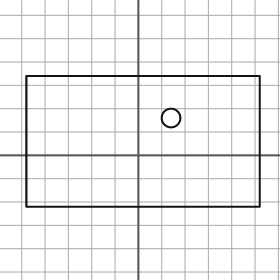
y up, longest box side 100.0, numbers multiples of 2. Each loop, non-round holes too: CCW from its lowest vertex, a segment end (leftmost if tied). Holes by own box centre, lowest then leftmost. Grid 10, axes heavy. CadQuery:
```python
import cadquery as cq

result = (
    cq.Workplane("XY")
    .moveTo(-48.0, -22.0)
    .lineTo(52.0, -22.0)
    .lineTo(52.0, 34.0)
    .lineTo(-48.0, 34.0)
    .close()
    .moveTo(14.0, 16.0)
    .circle(4.0)
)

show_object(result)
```